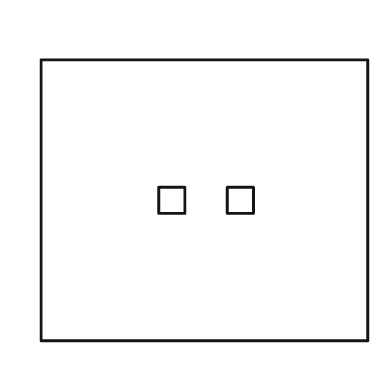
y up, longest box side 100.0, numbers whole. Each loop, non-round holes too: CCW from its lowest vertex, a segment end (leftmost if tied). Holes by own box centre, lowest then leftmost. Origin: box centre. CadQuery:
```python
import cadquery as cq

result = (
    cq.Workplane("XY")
    .moveTo(-50.0, -43.0)
    .lineTo(50.0, -43.0)
    .lineTo(50.0, 43.0)
    .lineTo(-50.0, 43.0)
    .close()
    .moveTo(-14.0, -4.0)
    .lineTo(-6.0, -4.0)
    .lineTo(-6.0, 4.0)
    .lineTo(-14.0, 4.0)
    .close()
    .moveTo(7.0, -4.0)
    .lineTo(15.0, -4.0)
    .lineTo(15.0, 4.0)
    .lineTo(7.0, 4.0)
    .close()
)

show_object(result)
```